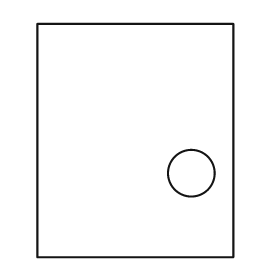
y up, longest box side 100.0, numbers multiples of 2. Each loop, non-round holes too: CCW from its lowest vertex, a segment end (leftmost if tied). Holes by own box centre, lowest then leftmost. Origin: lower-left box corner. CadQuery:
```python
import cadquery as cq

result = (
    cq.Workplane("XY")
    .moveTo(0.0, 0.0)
    .lineTo(84.0, 0.0)
    .lineTo(84.0, 100.0)
    .lineTo(0.0, 100.0)
    .close()
    .moveTo(66.0, 36.0)
    .circle(10.0)
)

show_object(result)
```